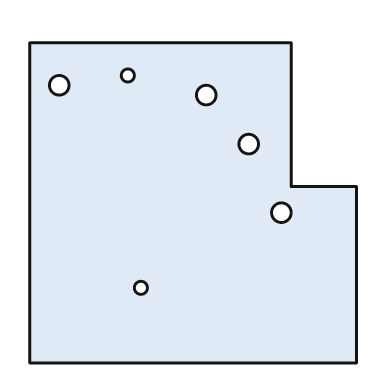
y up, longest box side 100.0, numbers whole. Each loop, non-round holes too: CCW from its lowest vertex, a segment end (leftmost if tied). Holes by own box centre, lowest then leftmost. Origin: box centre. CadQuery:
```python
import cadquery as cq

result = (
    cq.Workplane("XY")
    .moveTo(-50.0, -49.0)
    .lineTo(50.0, -49.0)
    .lineTo(50.0, 5.0)
    .lineTo(30.0, 5.0)
    .lineTo(30.0, 49.0)
    .lineTo(-50.0, 49.0)
    .close()
    .moveTo(-16.0, -26.0)
    .circle(2.0)
    .moveTo(27.0, -3.0)
    .circle(3.0)
    .moveTo(17.0, 18.0)
    .circle(3.0)
    .moveTo(4.0, 33.0)
    .circle(3.0)
    .moveTo(-41.0, 36.0)
    .circle(3.0)
    .moveTo(-20.0, 39.0)
    .circle(2.0)
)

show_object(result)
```